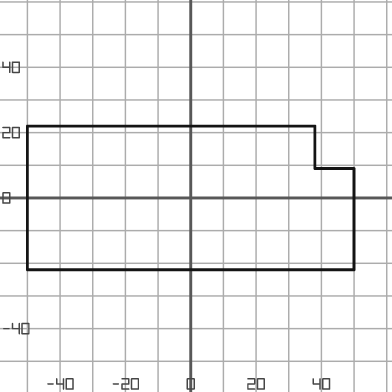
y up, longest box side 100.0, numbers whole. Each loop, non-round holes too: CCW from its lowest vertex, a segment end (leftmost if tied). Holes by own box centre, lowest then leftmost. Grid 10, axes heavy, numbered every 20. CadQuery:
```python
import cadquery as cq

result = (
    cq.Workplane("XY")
    .moveTo(-50.0, -22.0)
    .lineTo(50.0, -22.0)
    .lineTo(50.0, 9.0)
    .lineTo(38.0, 9.0)
    .lineTo(38.0, 22.0)
    .lineTo(-50.0, 22.0)
    .close()
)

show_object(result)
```